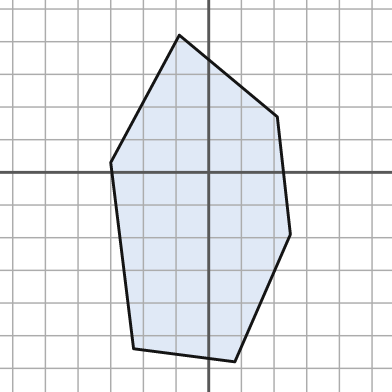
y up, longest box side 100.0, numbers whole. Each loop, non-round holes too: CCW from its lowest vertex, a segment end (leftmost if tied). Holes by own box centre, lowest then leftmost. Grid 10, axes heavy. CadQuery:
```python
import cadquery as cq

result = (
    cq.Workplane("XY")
    .moveTo(8.0, -58.0)
    .lineTo(25.0, -19.0)
    .lineTo(21.0, 17.0)
    .lineTo(-9.0, 42.0)
    .lineTo(-30.0, 3.0)
    .lineTo(-23.0, -54.0)
    .close()
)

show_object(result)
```